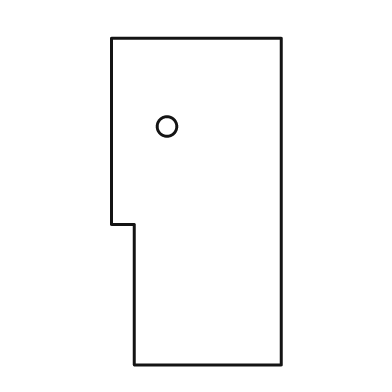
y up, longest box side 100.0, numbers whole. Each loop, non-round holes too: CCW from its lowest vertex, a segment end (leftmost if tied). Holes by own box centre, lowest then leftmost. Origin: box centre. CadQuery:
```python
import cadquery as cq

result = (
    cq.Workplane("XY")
    .moveTo(-19.0, -50.0)
    .lineTo(26.0, -50.0)
    .lineTo(26.0, 50.0)
    .lineTo(-26.0, 50.0)
    .lineTo(-26.0, -7.0)
    .lineTo(-19.0, -7.0)
    .close()
    .moveTo(-9.0, 23.0)
    .circle(3.0)
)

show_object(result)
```